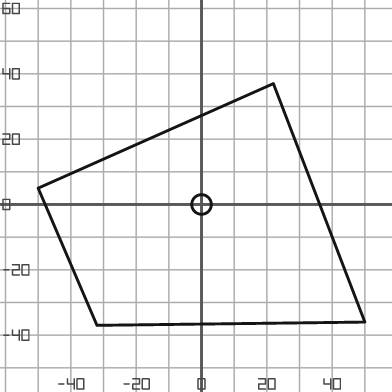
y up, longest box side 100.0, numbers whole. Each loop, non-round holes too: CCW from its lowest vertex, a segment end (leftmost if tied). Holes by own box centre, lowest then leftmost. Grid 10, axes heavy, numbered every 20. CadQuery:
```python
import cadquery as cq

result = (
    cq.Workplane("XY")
    .moveTo(-32.0, -37.0)
    .lineTo(50.0, -36.0)
    .lineTo(22.0, 37.0)
    .lineTo(-50.0, 5.0)
    .close()
    .moveTo(0.0, 0.0)
    .circle(3.0)
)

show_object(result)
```